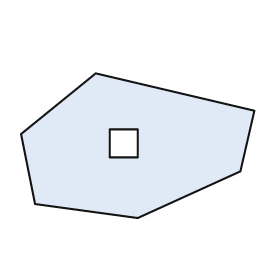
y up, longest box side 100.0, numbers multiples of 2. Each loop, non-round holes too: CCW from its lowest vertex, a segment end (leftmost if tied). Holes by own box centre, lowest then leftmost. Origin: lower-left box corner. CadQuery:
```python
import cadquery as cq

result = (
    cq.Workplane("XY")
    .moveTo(50.0, 0.0)
    .lineTo(94.0, 20.0)
    .lineTo(100.0, 46.0)
    .lineTo(32.0, 62.0)
    .lineTo(0.0, 36.0)
    .lineTo(6.0, 6.0)
    .close()
    .moveTo(38.0, 26.0)
    .lineTo(50.0, 26.0)
    .lineTo(50.0, 38.0)
    .lineTo(38.0, 38.0)
    .close()
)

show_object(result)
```